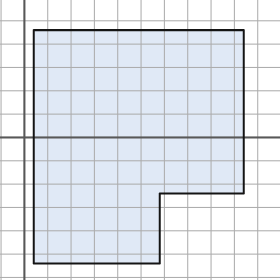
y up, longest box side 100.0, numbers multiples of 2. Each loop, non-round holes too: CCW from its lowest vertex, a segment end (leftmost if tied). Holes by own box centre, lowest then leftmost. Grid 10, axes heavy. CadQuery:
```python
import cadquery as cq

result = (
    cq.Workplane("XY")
    .moveTo(4.0, -54.0)
    .lineTo(58.0, -54.0)
    .lineTo(58.0, -24.0)
    .lineTo(94.0, -24.0)
    .lineTo(94.0, 46.0)
    .lineTo(4.0, 46.0)
    .close()
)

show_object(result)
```